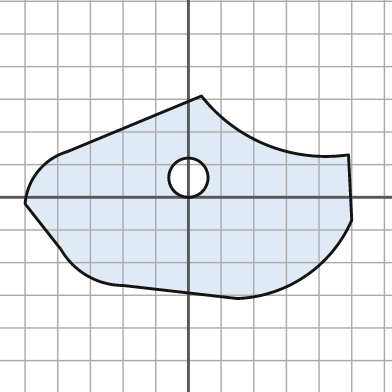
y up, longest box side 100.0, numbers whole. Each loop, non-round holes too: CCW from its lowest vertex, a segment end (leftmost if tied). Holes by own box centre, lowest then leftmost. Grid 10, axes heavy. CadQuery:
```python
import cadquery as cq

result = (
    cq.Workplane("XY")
    .moveTo(15.0, -31.0)
    .threePointArc((36.0, -24.0), (50.0, -7.0))
    .lineTo(49.0, 13.0)
    .threePointArc((24.0, 16.0), (4.0, 31.0))
    .lineTo(-37.0, 14.0)
    .threePointArc((-46.0, 8.0), (-50.0, -2.0))
    .lineTo(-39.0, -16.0)
    .threePointArc((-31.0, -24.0), (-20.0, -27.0))
    .close()
    .moveTo(0.0, 6.0)
    .circle(6.0)
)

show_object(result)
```